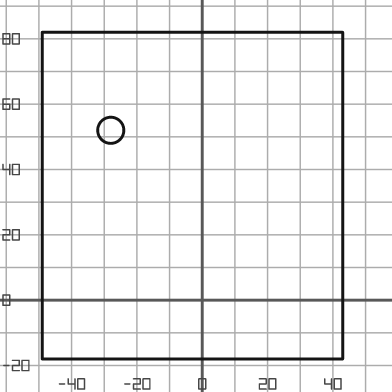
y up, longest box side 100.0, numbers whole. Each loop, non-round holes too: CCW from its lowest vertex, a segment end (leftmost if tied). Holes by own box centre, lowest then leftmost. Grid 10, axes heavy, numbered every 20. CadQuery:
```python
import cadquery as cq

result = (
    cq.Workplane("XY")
    .moveTo(-49.0, -18.0)
    .lineTo(43.0, -18.0)
    .lineTo(43.0, 82.0)
    .lineTo(-49.0, 82.0)
    .close()
    .moveTo(-28.0, 52.0)
    .circle(4.0)
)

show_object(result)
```